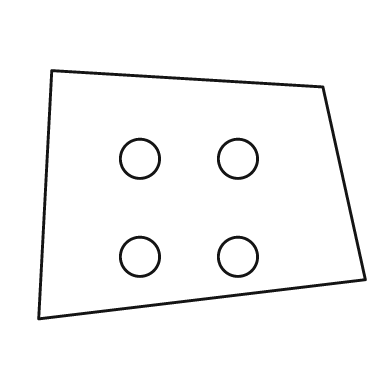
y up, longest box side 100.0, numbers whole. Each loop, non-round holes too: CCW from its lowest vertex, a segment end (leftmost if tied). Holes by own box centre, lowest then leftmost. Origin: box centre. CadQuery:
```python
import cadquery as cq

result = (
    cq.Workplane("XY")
    .moveTo(-50.0, -38.0)
    .lineTo(50.0, -26.0)
    .lineTo(37.0, 33.0)
    .lineTo(-46.0, 38.0)
    .close()
    .moveTo(-19.0, -19.0)
    .circle(6.0)
    .moveTo(11.0, -19.0)
    .circle(6.0)
    .moveTo(-19.0, 11.0)
    .circle(6.0)
    .moveTo(11.0, 11.0)
    .circle(6.0)
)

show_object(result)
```